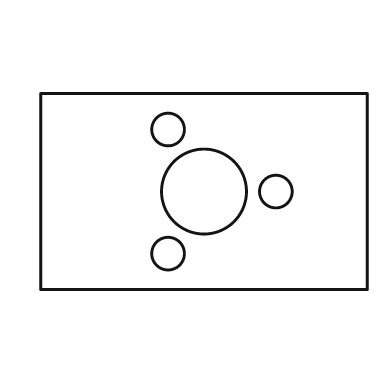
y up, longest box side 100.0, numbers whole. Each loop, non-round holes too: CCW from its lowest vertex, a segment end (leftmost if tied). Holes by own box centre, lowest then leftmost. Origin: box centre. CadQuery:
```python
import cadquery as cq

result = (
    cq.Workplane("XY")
    .moveTo(-50.0, -30.0)
    .lineTo(50.0, -30.0)
    .lineTo(50.0, 30.0)
    .lineTo(-50.0, 30.0)
    .close()
    .moveTo(-11.0, -19.0)
    .circle(5.0)
    .moveTo(0.0, 0.0)
    .circle(13.0)
    .moveTo(22.0, 0.0)
    .circle(5.0)
    .moveTo(-11.0, 19.0)
    .circle(5.0)
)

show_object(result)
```